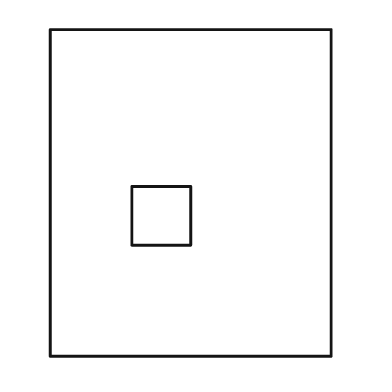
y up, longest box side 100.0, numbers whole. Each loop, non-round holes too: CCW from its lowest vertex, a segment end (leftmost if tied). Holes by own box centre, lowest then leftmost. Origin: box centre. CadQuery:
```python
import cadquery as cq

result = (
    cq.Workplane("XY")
    .moveTo(-43.0, -50.0)
    .lineTo(43.0, -50.0)
    .lineTo(43.0, 50.0)
    .lineTo(-43.0, 50.0)
    .close()
    .moveTo(-18.0, -16.0)
    .lineTo(0.0, -16.0)
    .lineTo(0.0, 2.0)
    .lineTo(-18.0, 2.0)
    .close()
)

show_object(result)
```